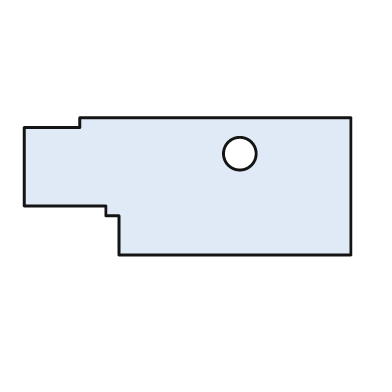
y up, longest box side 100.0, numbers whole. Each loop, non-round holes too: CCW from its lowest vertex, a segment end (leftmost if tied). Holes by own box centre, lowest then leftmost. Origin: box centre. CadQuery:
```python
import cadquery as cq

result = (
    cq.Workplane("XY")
    .moveTo(-21.0, -21.0)
    .lineTo(50.0, -21.0)
    .lineTo(50.0, 21.0)
    .lineTo(-33.0, 21.0)
    .lineTo(-33.0, 18.0)
    .lineTo(-50.0, 18.0)
    .lineTo(-50.0, -6.0)
    .lineTo(-25.0, -6.0)
    .lineTo(-25.0, -9.0)
    .lineTo(-21.0, -9.0)
    .close()
    .moveTo(16.0, 10.0)
    .circle(5.0)
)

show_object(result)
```